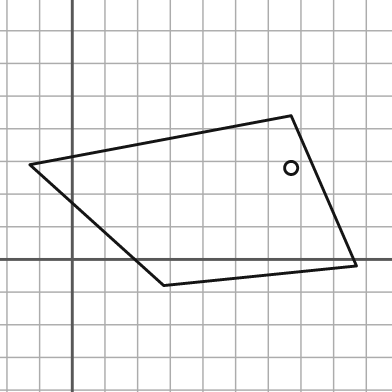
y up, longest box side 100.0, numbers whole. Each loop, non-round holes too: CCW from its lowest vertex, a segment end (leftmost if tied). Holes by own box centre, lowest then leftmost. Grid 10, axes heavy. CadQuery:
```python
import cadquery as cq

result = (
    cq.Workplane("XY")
    .moveTo(28.0, -8.0)
    .lineTo(87.0, -2.0)
    .lineTo(67.0, 44.0)
    .lineTo(-13.0, 29.0)
    .close()
    .moveTo(67.0, 28.0)
    .circle(2.0)
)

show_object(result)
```